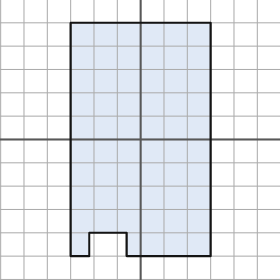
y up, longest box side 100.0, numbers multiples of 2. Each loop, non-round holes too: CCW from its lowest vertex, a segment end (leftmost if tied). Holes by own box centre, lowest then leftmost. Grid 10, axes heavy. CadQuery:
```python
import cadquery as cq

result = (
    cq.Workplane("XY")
    .moveTo(-30.0, -50.0)
    .lineTo(-22.0, -50.0)
    .lineTo(-22.0, -40.0)
    .lineTo(-6.0, -40.0)
    .lineTo(-6.0, -50.0)
    .lineTo(30.0, -50.0)
    .lineTo(30.0, 50.0)
    .lineTo(-30.0, 50.0)
    .close()
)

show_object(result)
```